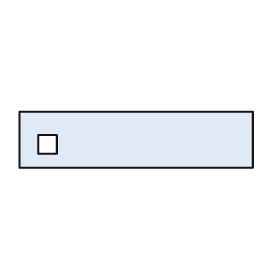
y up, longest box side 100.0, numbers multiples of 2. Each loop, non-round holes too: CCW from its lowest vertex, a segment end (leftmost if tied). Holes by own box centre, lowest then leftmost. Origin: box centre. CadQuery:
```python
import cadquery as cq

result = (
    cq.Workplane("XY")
    .moveTo(-50.0, -12.0)
    .lineTo(50.0, -12.0)
    .lineTo(50.0, 12.0)
    .lineTo(-50.0, 12.0)
    .close()
    .moveTo(-42.0, -6.0)
    .lineTo(-34.0, -6.0)
    .lineTo(-34.0, 2.0)
    .lineTo(-42.0, 2.0)
    .close()
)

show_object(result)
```